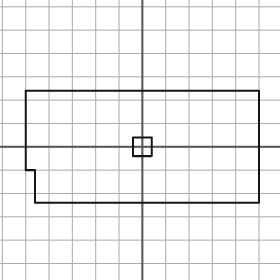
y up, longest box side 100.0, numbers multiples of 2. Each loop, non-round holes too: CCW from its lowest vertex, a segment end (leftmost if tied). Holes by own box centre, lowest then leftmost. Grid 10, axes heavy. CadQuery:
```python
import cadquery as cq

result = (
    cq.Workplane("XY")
    .moveTo(-46.0, -24.0)
    .lineTo(50.0, -24.0)
    .lineTo(50.0, 24.0)
    .lineTo(-50.0, 24.0)
    .lineTo(-50.0, -10.0)
    .lineTo(-46.0, -10.0)
    .close()
    .moveTo(-4.0, -4.0)
    .lineTo(4.0, -4.0)
    .lineTo(4.0, 4.0)
    .lineTo(-4.0, 4.0)
    .close()
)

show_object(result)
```